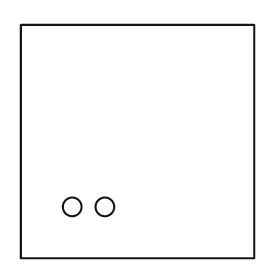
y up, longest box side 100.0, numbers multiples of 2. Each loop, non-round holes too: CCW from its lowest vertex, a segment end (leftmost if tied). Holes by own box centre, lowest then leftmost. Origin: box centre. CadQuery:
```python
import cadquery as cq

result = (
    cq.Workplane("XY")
    .moveTo(-50.0, -50.0)
    .lineTo(50.0, -50.0)
    .lineTo(50.0, 50.0)
    .lineTo(-50.0, 50.0)
    .close()
    .moveTo(-28.0, -28.0)
    .circle(4.0)
    .moveTo(-14.0, -28.0)
    .circle(4.0)
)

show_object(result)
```